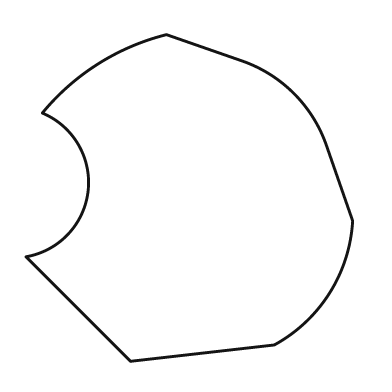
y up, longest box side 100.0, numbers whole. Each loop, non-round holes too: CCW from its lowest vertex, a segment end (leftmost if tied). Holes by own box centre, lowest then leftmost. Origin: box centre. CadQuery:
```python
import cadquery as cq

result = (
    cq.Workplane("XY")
    .moveTo(-18.0, -50.0)
    .lineTo(26.0, -45.0)
    .threePointArc((43.0, -29.0), (50.0, -7.0))
    .lineTo(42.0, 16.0)
    .threePointArc((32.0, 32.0), (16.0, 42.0))
    .lineTo(-7.0, 50.0)
    .threePointArc((-28.0, 41.0), (-45.0, 26.0))
    .threePointArc((-31.0, 2.0), (-50.0, -18.0))
    .close()
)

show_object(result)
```